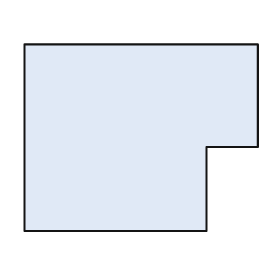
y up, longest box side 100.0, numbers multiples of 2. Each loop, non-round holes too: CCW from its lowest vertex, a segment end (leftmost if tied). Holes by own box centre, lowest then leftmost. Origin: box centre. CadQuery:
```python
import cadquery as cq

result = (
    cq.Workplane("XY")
    .moveTo(-50.0, -40.0)
    .lineTo(28.0, -40.0)
    .lineTo(28.0, -4.0)
    .lineTo(50.0, -4.0)
    .lineTo(50.0, 40.0)
    .lineTo(-50.0, 40.0)
    .close()
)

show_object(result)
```